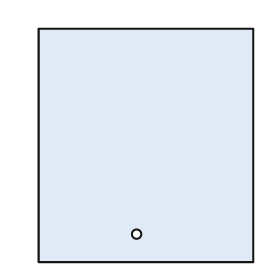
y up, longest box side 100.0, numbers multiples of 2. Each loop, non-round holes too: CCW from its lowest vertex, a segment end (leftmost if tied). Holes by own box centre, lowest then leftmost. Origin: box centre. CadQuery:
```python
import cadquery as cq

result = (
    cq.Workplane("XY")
    .moveTo(-46.0, -50.0)
    .lineTo(46.0, -50.0)
    .lineTo(46.0, 50.0)
    .lineTo(-46.0, 50.0)
    .close()
    .moveTo(-4.0, -38.0)
    .circle(2.0)
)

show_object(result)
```